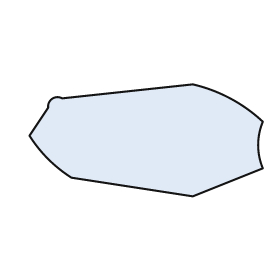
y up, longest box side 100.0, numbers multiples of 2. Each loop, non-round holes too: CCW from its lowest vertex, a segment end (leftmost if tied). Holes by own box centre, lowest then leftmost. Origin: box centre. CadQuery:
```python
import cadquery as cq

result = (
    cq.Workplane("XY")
    .moveTo(20.0, -24.0)
    .lineTo(50.0, -12.0)
    .threePointArc((48.0, -2.0), (50.0, 8.0))
    .threePointArc((36.0, 18.0), (20.0, 24.0))
    .lineTo(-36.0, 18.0)
    .threePointArc((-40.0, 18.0), (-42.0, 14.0))
    .lineTo(-50.0, 2.0)
    .threePointArc((-42.0, -8.0), (-32.0, -16.0))
    .close()
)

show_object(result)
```